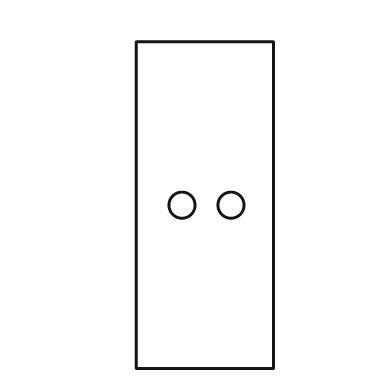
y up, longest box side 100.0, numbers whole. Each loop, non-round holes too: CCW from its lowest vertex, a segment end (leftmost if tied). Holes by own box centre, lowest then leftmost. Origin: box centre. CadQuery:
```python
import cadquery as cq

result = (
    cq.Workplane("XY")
    .moveTo(-21.0, -50.0)
    .lineTo(21.0, -50.0)
    .lineTo(21.0, 50.0)
    .lineTo(-21.0, 50.0)
    .close()
    .moveTo(-7.0, 0.0)
    .circle(4.0)
    .moveTo(8.0, 0.0)
    .circle(4.0)
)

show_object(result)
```